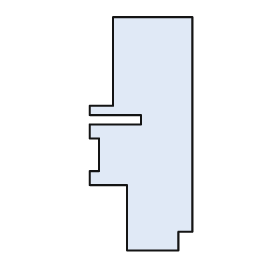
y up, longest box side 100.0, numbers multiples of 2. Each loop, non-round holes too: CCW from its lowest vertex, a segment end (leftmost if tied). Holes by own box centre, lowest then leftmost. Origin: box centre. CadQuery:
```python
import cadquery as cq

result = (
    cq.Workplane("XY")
    .moveTo(-6.0, -50.0)
    .lineTo(16.0, -50.0)
    .lineTo(16.0, -42.0)
    .lineTo(22.0, -42.0)
    .lineTo(22.0, 50.0)
    .lineTo(-12.0, 50.0)
    .lineTo(-12.0, 12.0)
    .lineTo(-22.0, 12.0)
    .lineTo(-22.0, 8.0)
    .lineTo(0.0, 8.0)
    .lineTo(0.0, 4.0)
    .lineTo(-22.0, 4.0)
    .lineTo(-22.0, -2.0)
    .lineTo(-18.0, -2.0)
    .lineTo(-18.0, -16.0)
    .lineTo(-22.0, -16.0)
    .lineTo(-22.0, -22.0)
    .lineTo(-6.0, -22.0)
    .close()
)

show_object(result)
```